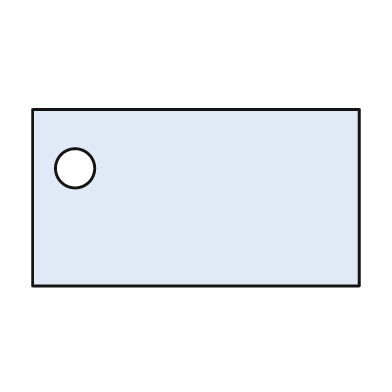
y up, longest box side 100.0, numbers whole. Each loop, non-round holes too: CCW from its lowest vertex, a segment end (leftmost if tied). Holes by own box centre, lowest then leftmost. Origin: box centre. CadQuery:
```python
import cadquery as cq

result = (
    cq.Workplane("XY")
    .moveTo(-50.0, -27.0)
    .lineTo(50.0, -27.0)
    .lineTo(50.0, 27.0)
    .lineTo(-50.0, 27.0)
    .close()
    .moveTo(-37.0, 9.0)
    .circle(6.0)
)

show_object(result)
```